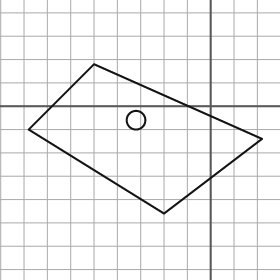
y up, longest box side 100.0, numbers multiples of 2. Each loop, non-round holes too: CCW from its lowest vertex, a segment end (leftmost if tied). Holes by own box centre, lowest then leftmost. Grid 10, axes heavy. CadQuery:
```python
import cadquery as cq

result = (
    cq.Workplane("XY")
    .moveTo(-20.0, -46.0)
    .lineTo(22.0, -14.0)
    .lineTo(-50.0, 18.0)
    .lineTo(-78.0, -10.0)
    .close()
    .moveTo(-32.0, -6.0)
    .circle(4.0)
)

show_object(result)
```